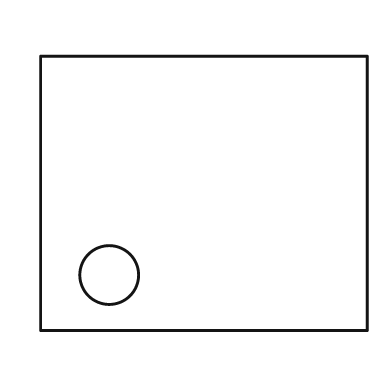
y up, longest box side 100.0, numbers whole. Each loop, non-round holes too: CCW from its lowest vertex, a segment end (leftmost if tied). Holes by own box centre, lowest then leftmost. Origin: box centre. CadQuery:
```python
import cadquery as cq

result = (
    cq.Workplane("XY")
    .moveTo(-50.0, -42.0)
    .lineTo(50.0, -42.0)
    .lineTo(50.0, 42.0)
    .lineTo(-50.0, 42.0)
    .close()
    .moveTo(-29.0, -25.0)
    .circle(9.0)
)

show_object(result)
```